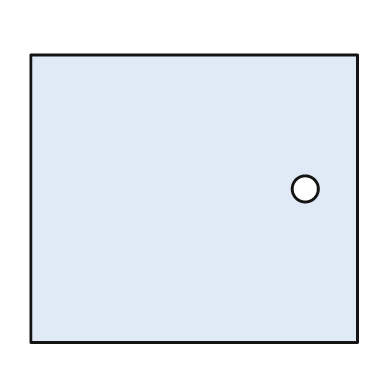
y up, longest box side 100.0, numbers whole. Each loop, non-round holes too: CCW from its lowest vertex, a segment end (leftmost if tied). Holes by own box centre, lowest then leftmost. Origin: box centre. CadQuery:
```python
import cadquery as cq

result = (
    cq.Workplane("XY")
    .moveTo(-50.0, -44.0)
    .lineTo(50.0, -44.0)
    .lineTo(50.0, 44.0)
    .lineTo(-50.0, 44.0)
    .close()
    .moveTo(34.0, 3.0)
    .circle(4.0)
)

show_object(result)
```